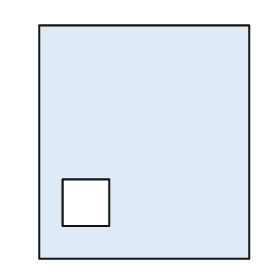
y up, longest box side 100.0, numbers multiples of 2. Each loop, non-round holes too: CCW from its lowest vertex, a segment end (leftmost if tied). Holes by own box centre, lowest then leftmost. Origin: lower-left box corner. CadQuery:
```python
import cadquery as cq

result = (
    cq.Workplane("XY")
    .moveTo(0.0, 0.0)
    .lineTo(90.0, 0.0)
    .lineTo(90.0, 100.0)
    .lineTo(0.0, 100.0)
    .close()
    .moveTo(10.0, 14.0)
    .lineTo(30.0, 14.0)
    .lineTo(30.0, 34.0)
    .lineTo(10.0, 34.0)
    .close()
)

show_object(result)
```